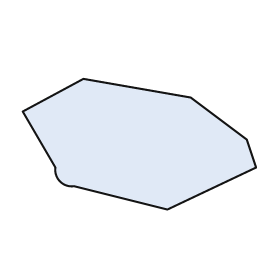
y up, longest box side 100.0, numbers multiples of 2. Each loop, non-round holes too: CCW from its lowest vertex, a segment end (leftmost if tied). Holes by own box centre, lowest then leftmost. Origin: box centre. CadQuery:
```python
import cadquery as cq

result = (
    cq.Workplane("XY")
    .moveTo(12.0, -28.0)
    .lineTo(50.0, -10.0)
    .lineTo(46.0, 2.0)
    .lineTo(22.0, 20.0)
    .lineTo(-24.0, 28.0)
    .lineTo(-50.0, 14.0)
    .lineTo(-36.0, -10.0)
    .threePointArc((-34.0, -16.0), (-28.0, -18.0))
    .close()
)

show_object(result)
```